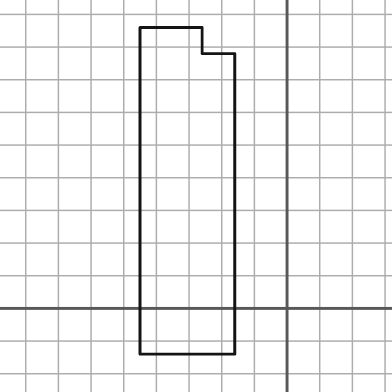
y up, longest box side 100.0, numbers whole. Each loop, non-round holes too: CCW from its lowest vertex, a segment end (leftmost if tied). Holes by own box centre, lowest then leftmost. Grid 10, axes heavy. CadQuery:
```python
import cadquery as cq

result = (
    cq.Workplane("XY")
    .moveTo(-45.0, -14.0)
    .lineTo(-16.0, -14.0)
    .lineTo(-16.0, 78.0)
    .lineTo(-26.0, 78.0)
    .lineTo(-26.0, 86.0)
    .lineTo(-45.0, 86.0)
    .close()
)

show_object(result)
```